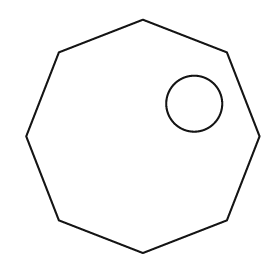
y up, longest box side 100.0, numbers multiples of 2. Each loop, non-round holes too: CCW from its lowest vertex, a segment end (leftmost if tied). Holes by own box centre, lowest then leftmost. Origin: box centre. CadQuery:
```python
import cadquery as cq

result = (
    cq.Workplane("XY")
    .moveTo(0.0, -50.0)
    .lineTo(36.0, -36.0)
    .lineTo(50.0, 0.0)
    .lineTo(36.0, 36.0)
    .lineTo(0.0, 50.0)
    .lineTo(-36.0, 36.0)
    .lineTo(-50.0, 0.0)
    .lineTo(-36.0, -36.0)
    .close()
    .moveTo(22.0, 14.0)
    .circle(12.0)
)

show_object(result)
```